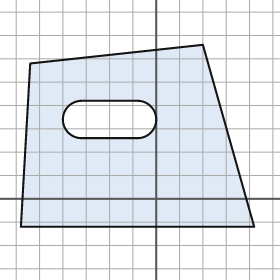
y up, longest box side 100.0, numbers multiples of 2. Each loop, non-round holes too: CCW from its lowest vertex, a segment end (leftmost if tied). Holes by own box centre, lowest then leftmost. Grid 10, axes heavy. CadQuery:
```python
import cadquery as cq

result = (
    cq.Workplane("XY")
    .moveTo(-58.0, -12.0)
    .lineTo(42.0, -12.0)
    .lineTo(20.0, 66.0)
    .lineTo(-54.0, 58.0)
    .close()
    .moveTo(-32.0, 26.0)
    .lineTo(-8.0, 26.0)
    .threePointArc((0.0, 34.0), (-8.0, 42.0))
    .lineTo(-32.0, 42.0)
    .threePointArc((-40.0, 34.0), (-32.0, 26.0))
    .close()
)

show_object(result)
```